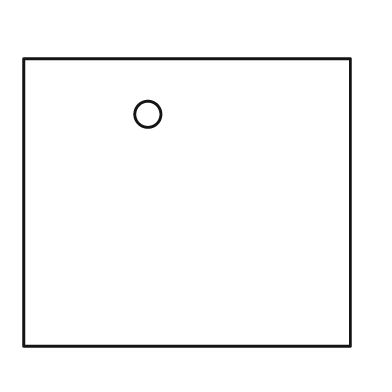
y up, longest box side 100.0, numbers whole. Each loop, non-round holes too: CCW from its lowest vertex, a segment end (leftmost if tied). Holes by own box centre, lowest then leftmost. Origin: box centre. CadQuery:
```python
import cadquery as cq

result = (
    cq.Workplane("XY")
    .moveTo(-50.0, -44.0)
    .lineTo(50.0, -44.0)
    .lineTo(50.0, 44.0)
    .lineTo(-50.0, 44.0)
    .close()
    .moveTo(-12.0, 27.0)
    .circle(4.0)
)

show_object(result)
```